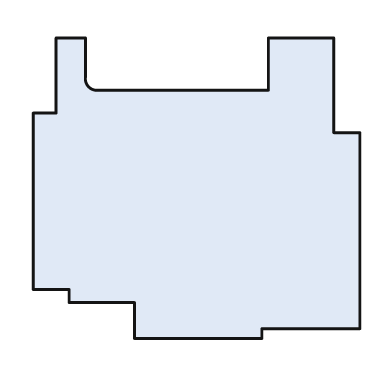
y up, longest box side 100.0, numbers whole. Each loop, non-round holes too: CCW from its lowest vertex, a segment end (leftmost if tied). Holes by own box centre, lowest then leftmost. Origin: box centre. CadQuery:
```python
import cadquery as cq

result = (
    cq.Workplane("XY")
    .moveTo(-19.0, -46.0)
    .lineTo(20.0, -46.0)
    .lineTo(20.0, -43.0)
    .lineTo(50.0, -43.0)
    .lineTo(50.0, 17.0)
    .lineTo(42.0, 17.0)
    .lineTo(42.0, 46.0)
    .lineTo(22.0, 46.0)
    .lineTo(22.0, 30.0)
    .lineTo(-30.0, 30.0)
    .threePointArc((-33.0, 31.0), (-34.0, 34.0))
    .lineTo(-34.0, 46.0)
    .lineTo(-43.0, 46.0)
    .lineTo(-43.0, 23.0)
    .lineTo(-50.0, 23.0)
    .lineTo(-50.0, -31.0)
    .lineTo(-39.0, -31.0)
    .lineTo(-39.0, -35.0)
    .lineTo(-19.0, -35.0)
    .close()
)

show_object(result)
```